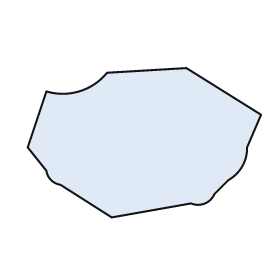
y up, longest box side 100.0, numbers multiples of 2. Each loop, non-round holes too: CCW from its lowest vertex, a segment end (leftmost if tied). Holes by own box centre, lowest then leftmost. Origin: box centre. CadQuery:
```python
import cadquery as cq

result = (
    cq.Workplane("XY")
    .moveTo(-14.0, -32.0)
    .lineTo(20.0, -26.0)
    .threePointArc((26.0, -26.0), (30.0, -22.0))
    .lineTo(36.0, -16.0)
    .threePointArc((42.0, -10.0), (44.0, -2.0))
    .lineTo(50.0, 12.0)
    .lineTo(18.0, 32.0)
    .lineTo(-16.0, 30.0)
    .threePointArc((-28.0, 22.0), (-42.0, 22.0))
    .lineTo(-50.0, -2.0)
    .lineTo(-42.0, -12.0)
    .threePointArc((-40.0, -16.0), (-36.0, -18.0))
    .close()
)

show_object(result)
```